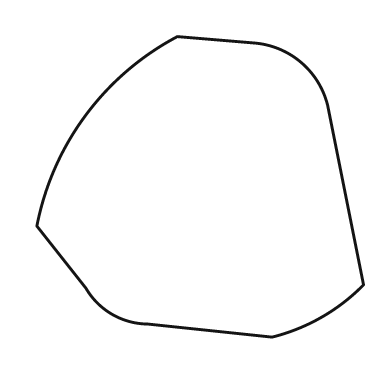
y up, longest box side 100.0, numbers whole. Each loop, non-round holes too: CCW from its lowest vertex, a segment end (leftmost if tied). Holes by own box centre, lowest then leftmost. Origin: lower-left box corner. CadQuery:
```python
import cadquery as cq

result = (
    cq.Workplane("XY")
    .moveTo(72.0, 0.0)
    .threePointArc((87.0, 6.0), (100.0, 16.0))
    .lineTo(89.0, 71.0)
    .threePointArc((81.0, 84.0), (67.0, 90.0))
    .lineTo(43.0, 92.0)
    .threePointArc((15.0, 68.0), (0.0, 34.0))
    .lineTo(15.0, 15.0)
    .threePointArc((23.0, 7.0), (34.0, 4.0))
    .close()
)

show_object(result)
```